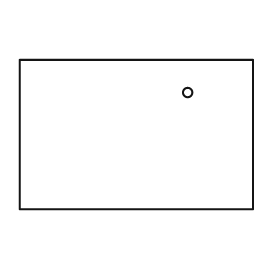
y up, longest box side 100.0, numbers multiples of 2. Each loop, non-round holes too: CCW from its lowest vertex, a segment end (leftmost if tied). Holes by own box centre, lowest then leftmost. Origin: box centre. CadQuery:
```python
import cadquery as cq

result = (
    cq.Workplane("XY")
    .moveTo(-50.0, -32.0)
    .lineTo(50.0, -32.0)
    .lineTo(50.0, 32.0)
    .lineTo(-50.0, 32.0)
    .close()
    .moveTo(22.0, 18.0)
    .circle(2.0)
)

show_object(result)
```